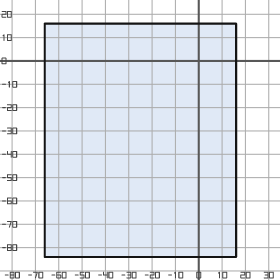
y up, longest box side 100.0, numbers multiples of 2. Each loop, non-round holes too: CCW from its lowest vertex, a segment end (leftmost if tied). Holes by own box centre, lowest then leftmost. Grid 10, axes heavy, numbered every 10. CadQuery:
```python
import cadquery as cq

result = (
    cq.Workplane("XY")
    .moveTo(-66.0, -84.0)
    .lineTo(16.0, -84.0)
    .lineTo(16.0, 16.0)
    .lineTo(-66.0, 16.0)
    .close()
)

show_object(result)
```